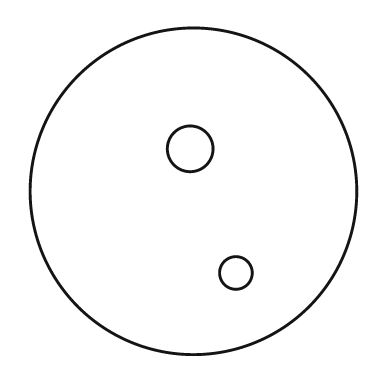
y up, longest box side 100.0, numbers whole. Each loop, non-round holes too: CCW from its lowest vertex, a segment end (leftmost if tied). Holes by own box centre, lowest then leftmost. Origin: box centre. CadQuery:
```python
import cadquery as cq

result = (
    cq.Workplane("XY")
    .moveTo(0.0, 0.0)
    .circle(50.0)
    .moveTo(13.0, -25.0)
    .circle(5.0)
    .moveTo(-1.0, 13.0)
    .circle(7.0)
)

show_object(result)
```